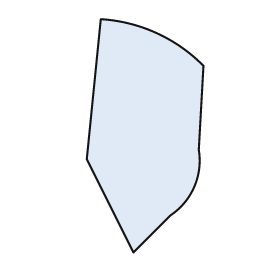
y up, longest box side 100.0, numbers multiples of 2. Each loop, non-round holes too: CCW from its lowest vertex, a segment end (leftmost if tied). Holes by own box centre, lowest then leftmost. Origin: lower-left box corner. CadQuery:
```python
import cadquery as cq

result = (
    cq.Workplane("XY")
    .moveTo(20.0, 0.0)
    .lineTo(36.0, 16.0)
    .threePointArc((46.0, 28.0), (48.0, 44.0))
    .lineTo(50.0, 80.0)
    .threePointArc((30.0, 94.0), (6.0, 100.0))
    .lineTo(0.0, 40.0)
    .close()
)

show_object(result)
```